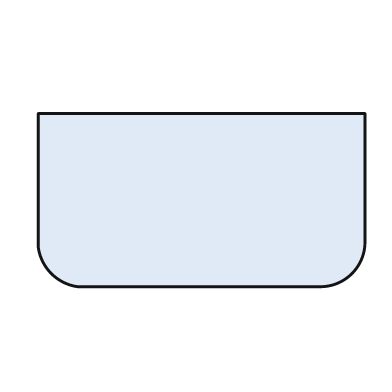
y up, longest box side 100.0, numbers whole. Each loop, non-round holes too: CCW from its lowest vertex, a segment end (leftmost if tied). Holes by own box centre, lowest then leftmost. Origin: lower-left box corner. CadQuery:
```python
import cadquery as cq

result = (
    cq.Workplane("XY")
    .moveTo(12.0, 0.0)
    .lineTo(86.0, 0.0)
    .threePointArc((96.0, 4.0), (100.0, 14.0))
    .lineTo(100.0, 53.0)
    .lineTo(0.0, 53.0)
    .lineTo(0.0, 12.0)
    .threePointArc((4.0, 4.0), (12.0, 0.0))
    .close()
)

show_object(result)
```